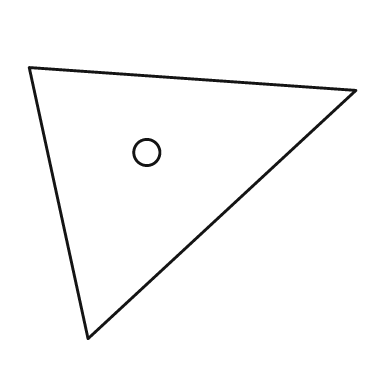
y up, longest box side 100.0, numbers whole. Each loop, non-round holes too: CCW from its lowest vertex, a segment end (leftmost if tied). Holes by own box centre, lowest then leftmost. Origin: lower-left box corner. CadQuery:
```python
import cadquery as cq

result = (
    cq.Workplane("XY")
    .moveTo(18.0, 0.0)
    .lineTo(100.0, 76.0)
    .lineTo(0.0, 83.0)
    .close()
    .moveTo(36.0, 57.0)
    .circle(4.0)
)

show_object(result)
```